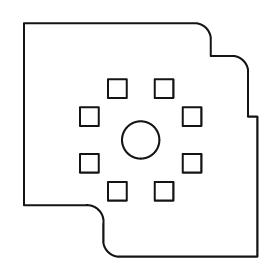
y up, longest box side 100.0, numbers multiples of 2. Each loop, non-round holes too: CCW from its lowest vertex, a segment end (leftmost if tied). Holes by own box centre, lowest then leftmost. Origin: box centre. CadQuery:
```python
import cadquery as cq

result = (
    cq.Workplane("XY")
    .moveTo(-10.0, -50.0)
    .lineTo(50.0, -50.0)
    .lineTo(50.0, 10.0)
    .lineTo(46.0, 10.0)
    .lineTo(46.0, 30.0)
    .threePointArc((44.0, 34.0), (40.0, 36.0))
    .lineTo(30.0, 36.0)
    .lineTo(30.0, 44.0)
    .threePointArc((28.0, 48.0), (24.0, 50.0))
    .lineTo(-50.0, 50.0)
    .lineTo(-50.0, -28.0)
    .lineTo(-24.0, -28.0)
    .threePointArc((-18.0, -30.0), (-16.0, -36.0))
    .lineTo(-16.0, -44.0)
    .threePointArc((-14.0, -48.0), (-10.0, -50.0))
    .close()
    .moveTo(-14.0, -26.0)
    .lineTo(-6.0, -26.0)
    .lineTo(-6.0, -18.0)
    .lineTo(-14.0, -18.0)
    .close()
    .moveTo(6.0, -26.0)
    .lineTo(14.0, -26.0)
    .lineTo(14.0, -18.0)
    .lineTo(6.0, -18.0)
    .close()
    .moveTo(-26.0, -14.0)
    .lineTo(-18.0, -14.0)
    .lineTo(-18.0, -6.0)
    .lineTo(-26.0, -6.0)
    .close()
    .moveTo(18.0, -14.0)
    .lineTo(26.0, -14.0)
    .lineTo(26.0, -6.0)
    .lineTo(18.0, -6.0)
    .close()
    .moveTo(0.0, 0.0)
    .circle(8.0)
    .moveTo(-26.0, 6.0)
    .lineTo(-18.0, 6.0)
    .lineTo(-18.0, 14.0)
    .lineTo(-26.0, 14.0)
    .close()
    .moveTo(18.0, 6.0)
    .lineTo(26.0, 6.0)
    .lineTo(26.0, 14.0)
    .lineTo(18.0, 14.0)
    .close()
    .moveTo(-14.0, 18.0)
    .lineTo(-6.0, 18.0)
    .lineTo(-6.0, 26.0)
    .lineTo(-14.0, 26.0)
    .close()
    .moveTo(6.0, 18.0)
    .lineTo(14.0, 18.0)
    .lineTo(14.0, 26.0)
    .lineTo(6.0, 26.0)
    .close()
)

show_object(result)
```